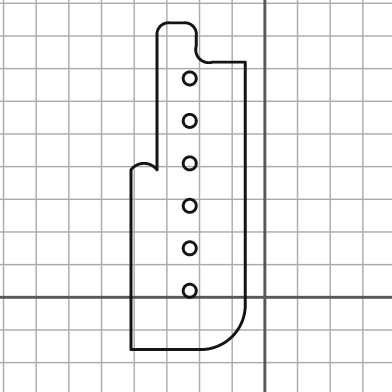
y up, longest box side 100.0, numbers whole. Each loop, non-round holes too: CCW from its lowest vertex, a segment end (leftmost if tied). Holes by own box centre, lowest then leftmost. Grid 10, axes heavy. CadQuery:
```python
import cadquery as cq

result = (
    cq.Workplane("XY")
    .moveTo(-41.0, -16.0)
    .lineTo(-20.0, -16.0)
    .threePointArc((-10.0, -12.0), (-6.0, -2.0))
    .lineTo(-6.0, 72.0)
    .lineTo(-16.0, 72.0)
    .threePointArc((-20.0, 73.0), (-21.0, 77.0))
    .lineTo(-21.0, 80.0)
    .threePointArc((-22.0, 83.0), (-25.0, 84.0))
    .lineTo(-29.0, 84.0)
    .threePointArc((-32.0, 83.0), (-33.0, 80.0))
    .lineTo(-33.0, 39.0)
    .threePointArc((-37.0, 41.0), (-41.0, 39.0))
    .close()
    .moveTo(-23.0, 2.0)
    .circle(2.0)
    .moveTo(-23.0, 15.0)
    .circle(2.0)
    .moveTo(-23.0, 28.0)
    .circle(2.0)
    .moveTo(-23.0, 41.0)
    .circle(2.0)
    .moveTo(-23.0, 54.0)
    .circle(2.0)
    .moveTo(-23.0, 67.0)
    .circle(2.0)
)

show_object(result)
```